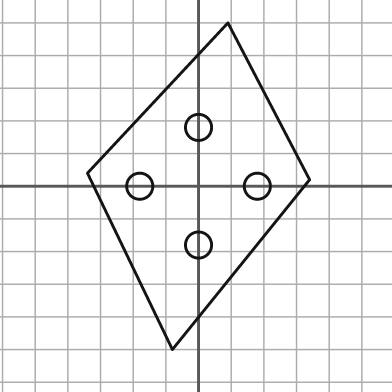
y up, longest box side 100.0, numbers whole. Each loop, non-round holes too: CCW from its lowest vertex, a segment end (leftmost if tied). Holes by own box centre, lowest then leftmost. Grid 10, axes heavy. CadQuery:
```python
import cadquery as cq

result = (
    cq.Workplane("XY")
    .moveTo(-8.0, -50.0)
    .lineTo(34.0, 2.0)
    .lineTo(9.0, 50.0)
    .lineTo(-34.0, 4.0)
    .close()
    .moveTo(0.0, -18.0)
    .circle(4.0)
    .moveTo(-18.0, 0.0)
    .circle(4.0)
    .moveTo(18.0, 0.0)
    .circle(4.0)
    .moveTo(0.0, 18.0)
    .circle(4.0)
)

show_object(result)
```